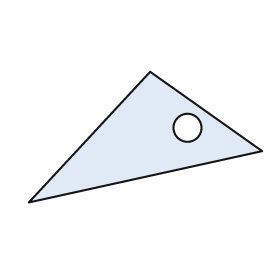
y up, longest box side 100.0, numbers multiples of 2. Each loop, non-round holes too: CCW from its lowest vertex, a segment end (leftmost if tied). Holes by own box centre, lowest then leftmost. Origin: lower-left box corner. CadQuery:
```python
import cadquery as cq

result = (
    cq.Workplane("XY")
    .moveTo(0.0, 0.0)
    .lineTo(100.0, 22.0)
    .lineTo(52.0, 56.0)
    .close()
    .moveTo(68.0, 32.0)
    .circle(6.0)
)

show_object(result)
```